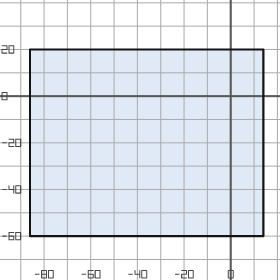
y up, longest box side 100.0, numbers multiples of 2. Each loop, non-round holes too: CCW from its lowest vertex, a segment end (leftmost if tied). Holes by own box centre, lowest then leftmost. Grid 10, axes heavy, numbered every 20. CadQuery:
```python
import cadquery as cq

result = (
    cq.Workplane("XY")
    .moveTo(-86.0, -60.0)
    .lineTo(14.0, -60.0)
    .lineTo(14.0, 20.0)
    .lineTo(-86.0, 20.0)
    .close()
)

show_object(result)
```